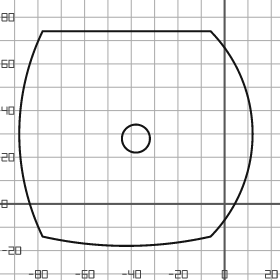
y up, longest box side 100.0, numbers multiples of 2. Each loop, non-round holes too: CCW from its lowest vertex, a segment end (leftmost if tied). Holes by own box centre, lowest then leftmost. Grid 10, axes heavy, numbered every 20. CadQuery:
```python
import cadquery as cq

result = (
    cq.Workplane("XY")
    .moveTo(-78.0, -14.0)
    .threePointArc((-42.0, -18.0), (-6.0, -14.0))
    .threePointArc((12.0, 30.0), (-6.0, 74.0))
    .lineTo(-78.0, 74.0)
    .threePointArc((-88.0, 30.0), (-78.0, -14.0))
    .close()
    .moveTo(-38.0, 28.0)
    .circle(6.0)
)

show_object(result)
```